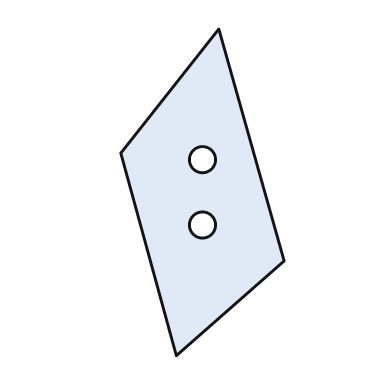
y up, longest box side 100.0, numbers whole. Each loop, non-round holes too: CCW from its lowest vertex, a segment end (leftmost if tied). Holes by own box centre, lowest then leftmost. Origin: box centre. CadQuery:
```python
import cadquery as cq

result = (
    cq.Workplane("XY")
    .moveTo(-8.0, -50.0)
    .lineTo(25.0, -21.0)
    .lineTo(5.0, 50.0)
    .lineTo(-25.0, 12.0)
    .close()
    .moveTo(0.0, -10.0)
    .circle(4.0)
    .moveTo(0.0, 10.0)
    .circle(4.0)
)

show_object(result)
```